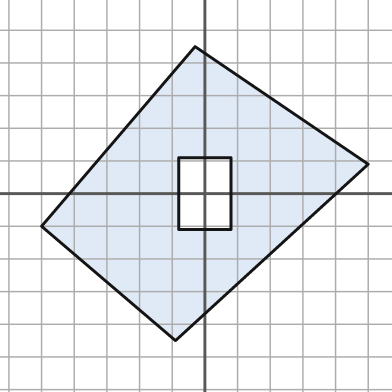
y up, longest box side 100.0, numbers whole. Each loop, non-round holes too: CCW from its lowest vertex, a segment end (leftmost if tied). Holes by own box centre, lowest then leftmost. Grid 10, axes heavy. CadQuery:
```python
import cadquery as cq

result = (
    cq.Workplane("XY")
    .moveTo(-9.0, -45.0)
    .lineTo(50.0, 9.0)
    .lineTo(-3.0, 45.0)
    .lineTo(-50.0, -10.0)
    .close()
    .moveTo(-8.0, -11.0)
    .lineTo(8.0, -11.0)
    .lineTo(8.0, 11.0)
    .lineTo(-8.0, 11.0)
    .close()
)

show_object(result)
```